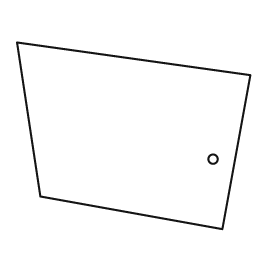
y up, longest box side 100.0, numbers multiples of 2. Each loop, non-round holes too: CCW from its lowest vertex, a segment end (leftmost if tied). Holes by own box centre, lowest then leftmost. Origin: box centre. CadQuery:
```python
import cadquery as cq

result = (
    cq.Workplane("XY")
    .moveTo(38.0, -40.0)
    .lineTo(50.0, 26.0)
    .lineTo(-50.0, 40.0)
    .lineTo(-40.0, -26.0)
    .close()
    .moveTo(34.0, -10.0)
    .circle(2.0)
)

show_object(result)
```